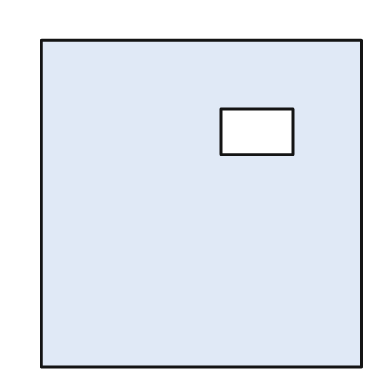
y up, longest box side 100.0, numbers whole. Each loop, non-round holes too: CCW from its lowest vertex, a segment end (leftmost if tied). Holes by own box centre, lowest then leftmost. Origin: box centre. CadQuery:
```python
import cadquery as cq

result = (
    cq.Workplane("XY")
    .moveTo(-49.0, -50.0)
    .lineTo(49.0, -50.0)
    .lineTo(49.0, 50.0)
    .lineTo(-49.0, 50.0)
    .close()
    .moveTo(6.0, 15.0)
    .lineTo(28.0, 15.0)
    .lineTo(28.0, 29.0)
    .lineTo(6.0, 29.0)
    .close()
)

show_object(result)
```